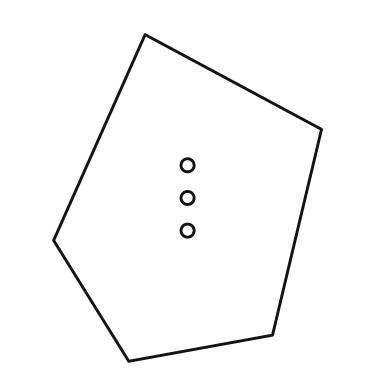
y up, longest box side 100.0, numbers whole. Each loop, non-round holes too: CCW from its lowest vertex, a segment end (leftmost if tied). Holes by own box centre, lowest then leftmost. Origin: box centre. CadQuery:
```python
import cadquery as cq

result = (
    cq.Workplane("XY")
    .moveTo(-18.0, -50.0)
    .lineTo(26.0, -42.0)
    .lineTo(41.0, 21.0)
    .lineTo(-13.0, 50.0)
    .lineTo(-41.0, -13.0)
    .close()
    .moveTo(0.0, -10.0)
    .circle(2.0)
    .moveTo(0.0, 0.0)
    .circle(2.0)
    .moveTo(0.0, 10.0)
    .circle(2.0)
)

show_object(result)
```